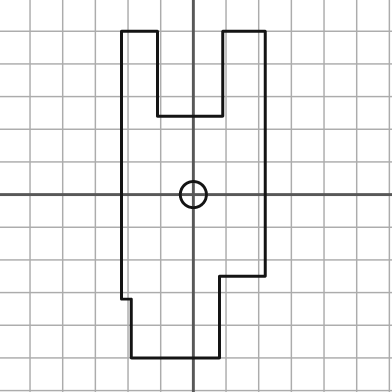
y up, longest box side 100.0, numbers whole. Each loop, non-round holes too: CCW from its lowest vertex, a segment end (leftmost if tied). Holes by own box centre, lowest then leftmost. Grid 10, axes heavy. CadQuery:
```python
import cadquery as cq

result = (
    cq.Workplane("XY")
    .moveTo(-19.0, -50.0)
    .lineTo(8.0, -50.0)
    .lineTo(8.0, -25.0)
    .lineTo(22.0, -25.0)
    .lineTo(22.0, 50.0)
    .lineTo(9.0, 50.0)
    .lineTo(9.0, 24.0)
    .lineTo(-11.0, 24.0)
    .lineTo(-11.0, 50.0)
    .lineTo(-22.0, 50.0)
    .lineTo(-22.0, -32.0)
    .lineTo(-19.0, -32.0)
    .close()
    .moveTo(0.0, 0.0)
    .circle(4.0)
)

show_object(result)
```